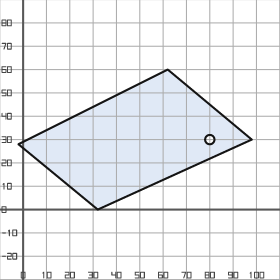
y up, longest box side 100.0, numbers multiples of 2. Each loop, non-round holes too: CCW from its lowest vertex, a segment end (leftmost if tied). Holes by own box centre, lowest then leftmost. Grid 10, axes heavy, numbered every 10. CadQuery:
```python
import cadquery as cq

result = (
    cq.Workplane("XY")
    .moveTo(32.0, 0.0)
    .lineTo(98.0, 30.0)
    .lineTo(62.0, 60.0)
    .lineTo(-2.0, 28.0)
    .close()
    .moveTo(80.0, 30.0)
    .circle(2.0)
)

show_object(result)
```